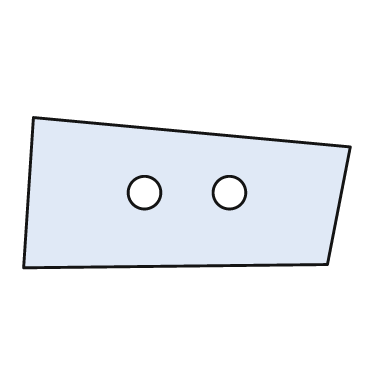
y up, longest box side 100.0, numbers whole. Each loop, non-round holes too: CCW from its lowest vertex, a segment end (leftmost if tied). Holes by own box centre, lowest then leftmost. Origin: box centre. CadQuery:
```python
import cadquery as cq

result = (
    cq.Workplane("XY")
    .moveTo(-50.0, -23.0)
    .lineTo(43.0, -22.0)
    .lineTo(50.0, 14.0)
    .lineTo(-47.0, 23.0)
    .close()
    .moveTo(-13.0, 0.0)
    .circle(5.0)
    .moveTo(13.0, 0.0)
    .circle(5.0)
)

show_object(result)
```